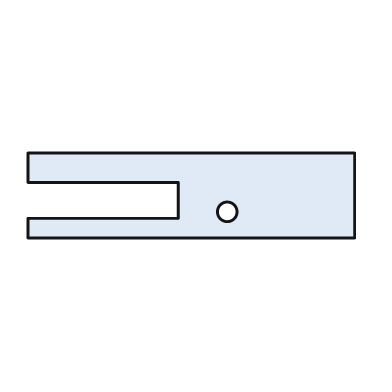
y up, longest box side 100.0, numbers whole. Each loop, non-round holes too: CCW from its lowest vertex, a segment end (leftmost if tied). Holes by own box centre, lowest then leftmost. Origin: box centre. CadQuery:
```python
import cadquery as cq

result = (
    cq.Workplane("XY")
    .moveTo(-50.0, -13.0)
    .lineTo(50.0, -13.0)
    .lineTo(50.0, 13.0)
    .lineTo(-50.0, 13.0)
    .lineTo(-50.0, 4.0)
    .lineTo(-4.0, 4.0)
    .lineTo(-4.0, -7.0)
    .lineTo(-50.0, -7.0)
    .close()
    .moveTo(11.0, -5.0)
    .circle(3.0)
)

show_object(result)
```